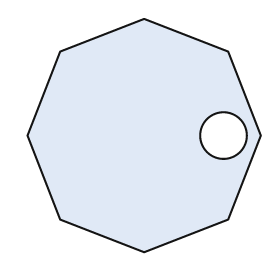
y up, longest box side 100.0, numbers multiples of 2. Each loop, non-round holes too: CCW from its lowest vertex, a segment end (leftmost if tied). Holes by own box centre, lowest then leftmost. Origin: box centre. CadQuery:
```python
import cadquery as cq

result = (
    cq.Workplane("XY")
    .moveTo(0.0, -50.0)
    .lineTo(36.0, -36.0)
    .lineTo(50.0, 0.0)
    .lineTo(36.0, 36.0)
    .lineTo(0.0, 50.0)
    .lineTo(-36.0, 36.0)
    .lineTo(-50.0, 0.0)
    .lineTo(-36.0, -36.0)
    .close()
    .moveTo(34.0, 0.0)
    .circle(10.0)
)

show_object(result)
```